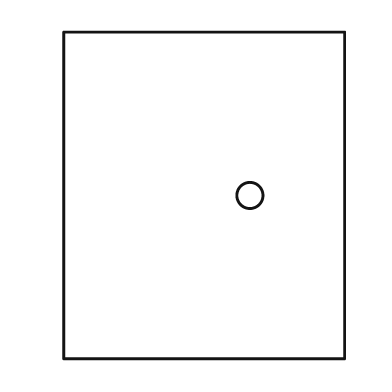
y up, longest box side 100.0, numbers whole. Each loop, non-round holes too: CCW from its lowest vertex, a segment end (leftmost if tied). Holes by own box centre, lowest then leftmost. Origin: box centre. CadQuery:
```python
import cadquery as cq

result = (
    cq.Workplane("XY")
    .moveTo(-43.0, -50.0)
    .lineTo(43.0, -50.0)
    .lineTo(43.0, 50.0)
    .lineTo(-43.0, 50.0)
    .close()
    .moveTo(14.0, 0.0)
    .circle(4.0)
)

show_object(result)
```